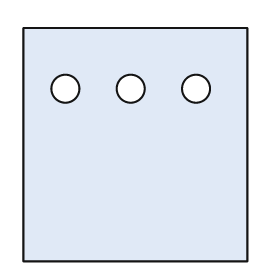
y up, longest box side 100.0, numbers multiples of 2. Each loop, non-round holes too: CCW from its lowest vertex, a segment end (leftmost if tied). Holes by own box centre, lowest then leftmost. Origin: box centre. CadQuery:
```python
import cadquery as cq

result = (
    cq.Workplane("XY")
    .moveTo(-48.0, -50.0)
    .lineTo(48.0, -50.0)
    .lineTo(48.0, 50.0)
    .lineTo(-48.0, 50.0)
    .close()
    .moveTo(-30.0, 24.0)
    .circle(6.0)
    .moveTo(-2.0, 24.0)
    .circle(6.0)
    .moveTo(26.0, 24.0)
    .circle(6.0)
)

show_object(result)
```